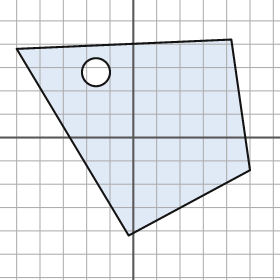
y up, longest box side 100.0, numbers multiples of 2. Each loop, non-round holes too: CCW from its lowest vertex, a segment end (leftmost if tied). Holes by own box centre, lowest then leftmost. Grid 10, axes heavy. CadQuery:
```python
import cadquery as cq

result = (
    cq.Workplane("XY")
    .moveTo(-2.0, -42.0)
    .lineTo(50.0, -14.0)
    .lineTo(42.0, 42.0)
    .lineTo(-50.0, 38.0)
    .close()
    .moveTo(-16.0, 28.0)
    .circle(6.0)
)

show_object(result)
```